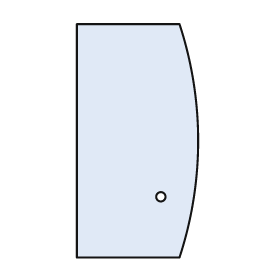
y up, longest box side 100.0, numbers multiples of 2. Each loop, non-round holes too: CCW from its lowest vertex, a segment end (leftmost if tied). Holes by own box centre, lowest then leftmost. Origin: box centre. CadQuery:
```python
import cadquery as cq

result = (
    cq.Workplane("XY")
    .moveTo(-26.0, -50.0)
    .lineTo(18.0, -50.0)
    .threePointArc((26.0, 0.0), (18.0, 50.0))
    .lineTo(-26.0, 50.0)
    .close()
    .moveTo(10.0, -24.0)
    .circle(2.0)
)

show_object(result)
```